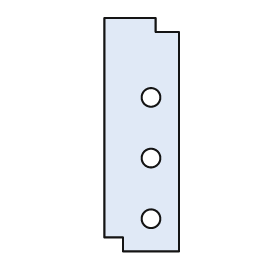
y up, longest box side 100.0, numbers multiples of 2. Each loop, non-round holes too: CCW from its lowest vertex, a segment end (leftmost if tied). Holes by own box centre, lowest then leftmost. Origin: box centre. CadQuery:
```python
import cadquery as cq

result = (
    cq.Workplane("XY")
    .moveTo(-8.0, -50.0)
    .lineTo(16.0, -50.0)
    .lineTo(16.0, 44.0)
    .lineTo(6.0, 44.0)
    .lineTo(6.0, 50.0)
    .lineTo(-16.0, 50.0)
    .lineTo(-16.0, -44.0)
    .lineTo(-8.0, -44.0)
    .close()
    .moveTo(4.0, -36.0)
    .circle(4.0)
    .moveTo(4.0, -10.0)
    .circle(4.0)
    .moveTo(4.0, 16.0)
    .circle(4.0)
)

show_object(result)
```